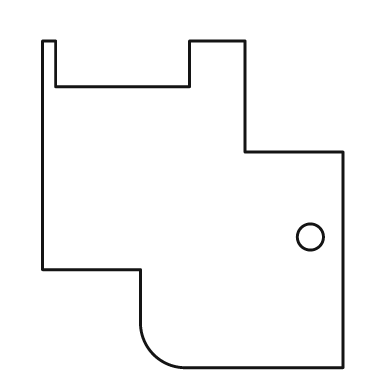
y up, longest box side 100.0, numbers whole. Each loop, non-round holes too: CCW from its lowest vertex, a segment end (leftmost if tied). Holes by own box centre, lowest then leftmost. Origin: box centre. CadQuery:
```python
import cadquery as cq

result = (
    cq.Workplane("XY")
    .moveTo(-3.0, -50.0)
    .lineTo(46.0, -50.0)
    .lineTo(46.0, 16.0)
    .lineTo(16.0, 16.0)
    .lineTo(16.0, 50.0)
    .lineTo(-1.0, 50.0)
    .lineTo(-1.0, 36.0)
    .lineTo(-42.0, 36.0)
    .lineTo(-42.0, 50.0)
    .lineTo(-46.0, 50.0)
    .lineTo(-46.0, -20.0)
    .lineTo(-16.0, -20.0)
    .lineTo(-16.0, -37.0)
    .threePointArc((-12.0, -46.0), (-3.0, -50.0))
    .close()
    .moveTo(36.0, -10.0)
    .circle(4.0)
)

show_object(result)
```